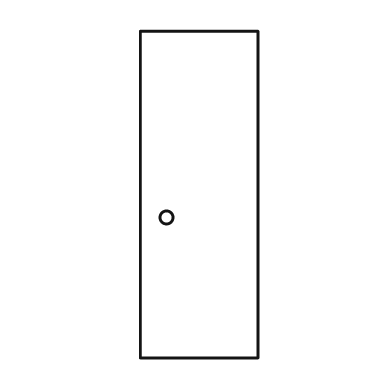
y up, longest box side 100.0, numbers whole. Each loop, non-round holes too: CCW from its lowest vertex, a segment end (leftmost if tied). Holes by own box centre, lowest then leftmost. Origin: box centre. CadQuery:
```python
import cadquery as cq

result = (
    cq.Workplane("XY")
    .moveTo(-18.0, -50.0)
    .lineTo(18.0, -50.0)
    .lineTo(18.0, 50.0)
    .lineTo(-18.0, 50.0)
    .close()
    .moveTo(-10.0, -7.0)
    .circle(2.0)
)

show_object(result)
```